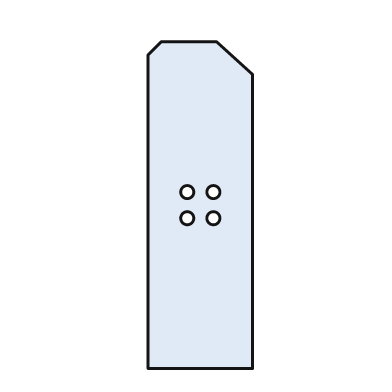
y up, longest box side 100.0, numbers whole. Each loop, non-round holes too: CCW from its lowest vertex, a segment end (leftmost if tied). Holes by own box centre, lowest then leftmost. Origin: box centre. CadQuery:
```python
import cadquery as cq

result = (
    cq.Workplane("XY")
    .moveTo(-16.0, -50.0)
    .lineTo(16.0, -50.0)
    .lineTo(16.0, 40.0)
    .lineTo(5.0, 50.0)
    .lineTo(-12.0, 50.0)
    .lineTo(-16.0, 46.0)
    .close()
    .moveTo(-4.0, -4.0)
    .circle(2.0)
    .moveTo(4.0, -4.0)
    .circle(2.0)
    .moveTo(-4.0, 4.0)
    .circle(2.0)
    .moveTo(4.0, 4.0)
    .circle(2.0)
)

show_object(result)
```